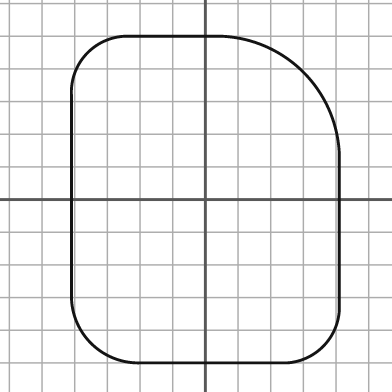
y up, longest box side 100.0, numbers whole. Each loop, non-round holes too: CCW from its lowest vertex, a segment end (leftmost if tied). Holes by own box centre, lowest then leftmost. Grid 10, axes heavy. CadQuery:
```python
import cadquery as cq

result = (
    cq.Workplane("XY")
    .moveTo(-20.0, -50.0)
    .lineTo(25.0, -50.0)
    .threePointArc((36.0, -45.0), (41.0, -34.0))
    .lineTo(41.0, 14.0)
    .threePointArc((30.0, 39.0), (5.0, 50.0))
    .lineTo(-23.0, 50.0)
    .threePointArc((-36.0, 45.0), (-41.0, 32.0))
    .lineTo(-41.0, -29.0)
    .threePointArc((-35.0, -44.0), (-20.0, -50.0))
    .close()
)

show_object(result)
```